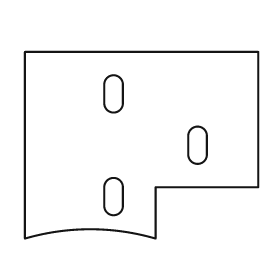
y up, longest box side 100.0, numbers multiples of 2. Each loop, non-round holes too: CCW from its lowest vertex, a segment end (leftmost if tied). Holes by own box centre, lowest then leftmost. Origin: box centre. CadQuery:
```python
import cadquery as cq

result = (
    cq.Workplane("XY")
    .moveTo(-50.0, -40.0)
    .threePointArc((-22.0, -36.0), (6.0, -40.0))
    .lineTo(6.0, -18.0)
    .lineTo(50.0, -18.0)
    .lineTo(50.0, 40.0)
    .lineTo(-50.0, 40.0)
    .close()
    .moveTo(-16.0, -26.0)
    .threePointArc((-12.0, -30.0), (-8.0, -26.0))
    .lineTo(-8.0, -18.0)
    .threePointArc((-12.0, -14.0), (-16.0, -18.0))
    .close()
    .moveTo(20.0, -4.0)
    .threePointArc((24.0, -8.0), (28.0, -4.0))
    .lineTo(28.0, 4.0)
    .threePointArc((24.0, 8.0), (20.0, 4.0))
    .close()
    .moveTo(-16.0, 18.0)
    .threePointArc((-12.0, 14.0), (-8.0, 18.0))
    .lineTo(-8.0, 26.0)
    .threePointArc((-12.0, 30.0), (-16.0, 26.0))
    .close()
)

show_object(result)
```